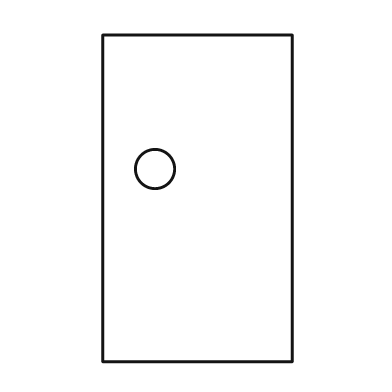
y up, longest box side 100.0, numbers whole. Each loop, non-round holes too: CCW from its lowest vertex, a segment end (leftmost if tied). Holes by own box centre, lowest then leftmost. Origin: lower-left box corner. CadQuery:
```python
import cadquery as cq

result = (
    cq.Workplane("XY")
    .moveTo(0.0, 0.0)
    .lineTo(58.0, 0.0)
    .lineTo(58.0, 100.0)
    .lineTo(0.0, 100.0)
    .close()
    .moveTo(16.0, 59.0)
    .circle(6.0)
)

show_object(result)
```